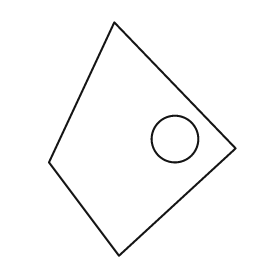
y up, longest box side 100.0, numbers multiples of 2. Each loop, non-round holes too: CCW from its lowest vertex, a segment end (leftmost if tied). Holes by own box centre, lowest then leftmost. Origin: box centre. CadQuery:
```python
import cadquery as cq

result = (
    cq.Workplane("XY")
    .moveTo(-10.0, -50.0)
    .lineTo(40.0, -4.0)
    .lineTo(-12.0, 50.0)
    .lineTo(-40.0, -10.0)
    .close()
    .moveTo(14.0, 0.0)
    .circle(10.0)
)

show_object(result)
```